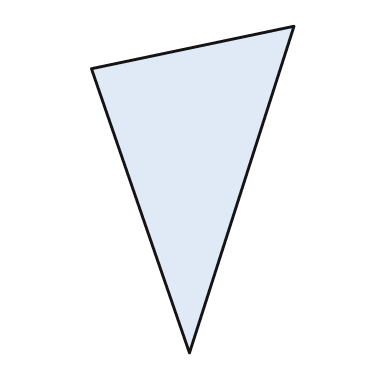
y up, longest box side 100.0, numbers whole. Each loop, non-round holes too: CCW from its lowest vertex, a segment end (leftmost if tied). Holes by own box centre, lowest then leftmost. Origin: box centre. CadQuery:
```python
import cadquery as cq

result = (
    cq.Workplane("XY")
    .moveTo(-1.0, -50.0)
    .lineTo(31.0, 50.0)
    .lineTo(-31.0, 37.0)
    .close()
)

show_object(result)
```